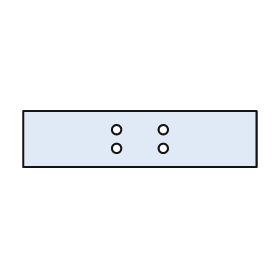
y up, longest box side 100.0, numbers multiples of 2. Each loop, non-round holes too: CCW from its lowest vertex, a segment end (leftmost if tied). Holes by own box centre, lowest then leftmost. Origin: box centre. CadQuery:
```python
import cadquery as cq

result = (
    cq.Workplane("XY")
    .moveTo(-50.0, -12.0)
    .lineTo(50.0, -12.0)
    .lineTo(50.0, 12.0)
    .lineTo(-50.0, 12.0)
    .close()
    .moveTo(-10.0, -4.0)
    .circle(2.0)
    .moveTo(10.0, -4.0)
    .circle(2.0)
    .moveTo(-10.0, 4.0)
    .circle(2.0)
    .moveTo(10.0, 4.0)
    .circle(2.0)
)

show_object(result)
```